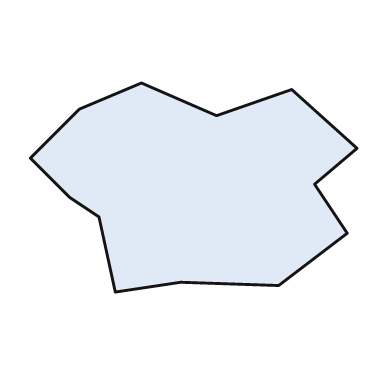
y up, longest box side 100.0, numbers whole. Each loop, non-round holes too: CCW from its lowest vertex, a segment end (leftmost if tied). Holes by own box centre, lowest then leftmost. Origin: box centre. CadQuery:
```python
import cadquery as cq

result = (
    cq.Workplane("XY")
    .moveTo(-24.0, -32.0)
    .lineTo(-4.0, -29.0)
    .lineTo(26.0, -30.0)
    .lineTo(47.0, -14.0)
    .lineTo(37.0, 1.0)
    .lineTo(50.0, 12.0)
    .lineTo(30.0, 30.0)
    .lineTo(7.0, 22.0)
    .lineTo(-16.0, 32.0)
    .lineTo(-35.0, 24.0)
    .lineTo(-50.0, 9.0)
    .lineTo(-38.0, -3.0)
    .lineTo(-29.0, -9.0)
    .close()
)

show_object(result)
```